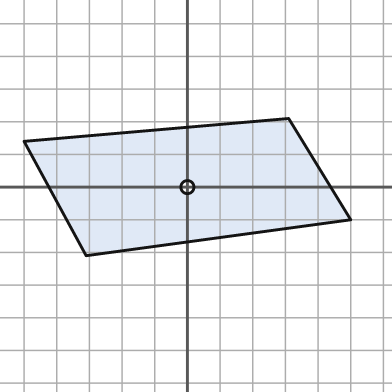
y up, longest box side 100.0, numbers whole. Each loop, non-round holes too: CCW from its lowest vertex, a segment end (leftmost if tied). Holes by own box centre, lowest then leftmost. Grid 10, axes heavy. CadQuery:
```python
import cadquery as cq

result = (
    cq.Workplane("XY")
    .moveTo(-31.0, -21.0)
    .lineTo(50.0, -10.0)
    .lineTo(31.0, 21.0)
    .lineTo(-50.0, 14.0)
    .close()
    .moveTo(0.0, 0.0)
    .circle(2.0)
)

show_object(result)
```